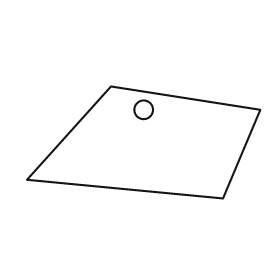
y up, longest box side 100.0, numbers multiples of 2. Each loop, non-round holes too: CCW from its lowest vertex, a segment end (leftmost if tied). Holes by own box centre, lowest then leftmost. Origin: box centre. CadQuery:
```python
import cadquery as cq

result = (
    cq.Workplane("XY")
    .moveTo(34.0, -24.0)
    .lineTo(50.0, 14.0)
    .lineTo(-14.0, 24.0)
    .lineTo(-50.0, -16.0)
    .close()
    .moveTo(0.0, 14.0)
    .circle(4.0)
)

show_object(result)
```